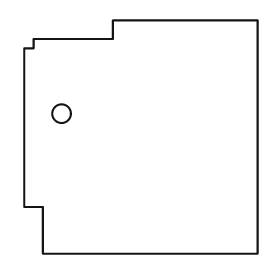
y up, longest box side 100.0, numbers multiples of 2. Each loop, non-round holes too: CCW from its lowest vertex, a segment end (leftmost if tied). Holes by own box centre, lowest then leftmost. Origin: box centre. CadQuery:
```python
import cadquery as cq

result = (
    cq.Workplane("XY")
    .moveTo(-42.0, -50.0)
    .lineTo(50.0, -50.0)
    .lineTo(50.0, 50.0)
    .lineTo(-12.0, 50.0)
    .lineTo(-12.0, 42.0)
    .lineTo(-46.0, 42.0)
    .lineTo(-46.0, 38.0)
    .lineTo(-50.0, 38.0)
    .lineTo(-50.0, -30.0)
    .lineTo(-42.0, -30.0)
    .close()
    .moveTo(-34.0, 10.0)
    .circle(4.0)
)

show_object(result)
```